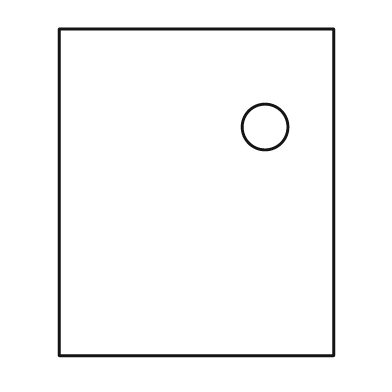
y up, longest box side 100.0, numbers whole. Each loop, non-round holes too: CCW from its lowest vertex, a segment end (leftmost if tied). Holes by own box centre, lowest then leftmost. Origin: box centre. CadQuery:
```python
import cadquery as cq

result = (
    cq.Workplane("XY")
    .moveTo(-42.0, -50.0)
    .lineTo(42.0, -50.0)
    .lineTo(42.0, 50.0)
    .lineTo(-42.0, 50.0)
    .close()
    .moveTo(21.0, 20.0)
    .circle(7.0)
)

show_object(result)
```